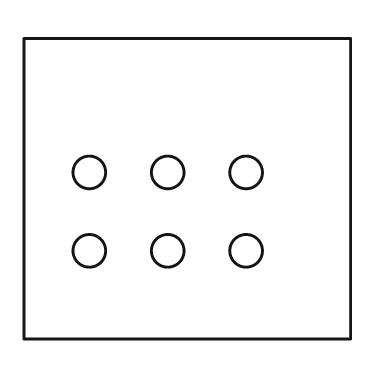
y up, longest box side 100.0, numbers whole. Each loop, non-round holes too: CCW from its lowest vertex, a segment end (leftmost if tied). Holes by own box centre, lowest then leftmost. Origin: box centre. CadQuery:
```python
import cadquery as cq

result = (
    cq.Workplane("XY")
    .moveTo(-50.0, -46.0)
    .lineTo(50.0, -46.0)
    .lineTo(50.0, 46.0)
    .lineTo(-50.0, 46.0)
    .close()
    .moveTo(-30.0, -19.0)
    .circle(5.0)
    .moveTo(-6.0, -19.0)
    .circle(5.0)
    .moveTo(18.0, -19.0)
    .circle(5.0)
    .moveTo(-30.0, 5.0)
    .circle(5.0)
    .moveTo(-6.0, 5.0)
    .circle(5.0)
    .moveTo(18.0, 5.0)
    .circle(5.0)
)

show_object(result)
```